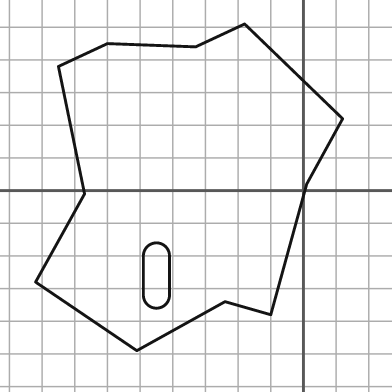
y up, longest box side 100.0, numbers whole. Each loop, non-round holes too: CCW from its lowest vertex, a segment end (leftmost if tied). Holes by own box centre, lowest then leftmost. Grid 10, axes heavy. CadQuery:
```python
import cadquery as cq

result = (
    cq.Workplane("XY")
    .moveTo(-51.0, -49.0)
    .lineTo(-24.0, -34.0)
    .lineTo(-10.0, -38.0)
    .lineTo(1.0, 2.0)
    .lineTo(12.0, 22.0)
    .lineTo(-18.0, 51.0)
    .lineTo(-33.0, 44.0)
    .lineTo(-60.0, 45.0)
    .lineTo(-75.0, 38.0)
    .lineTo(-67.0, -1.0)
    .lineTo(-82.0, -28.0)
    .close()
    .moveTo(-49.0, -32.0)
    .threePointArc((-45.0, -36.0), (-41.0, -32.0))
    .lineTo(-41.0, -20.0)
    .threePointArc((-45.0, -16.0), (-49.0, -20.0))
    .close()
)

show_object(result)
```